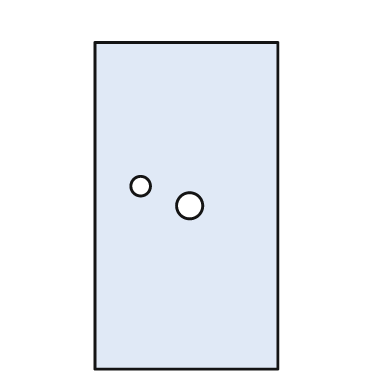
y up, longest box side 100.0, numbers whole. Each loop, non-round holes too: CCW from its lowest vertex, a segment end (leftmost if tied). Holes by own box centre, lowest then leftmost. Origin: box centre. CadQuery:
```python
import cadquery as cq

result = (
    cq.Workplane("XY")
    .moveTo(-28.0, -50.0)
    .lineTo(28.0, -50.0)
    .lineTo(28.0, 50.0)
    .lineTo(-28.0, 50.0)
    .close()
    .moveTo(1.0, 0.0)
    .circle(4.0)
    .moveTo(-14.0, 6.0)
    .circle(3.0)
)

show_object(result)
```